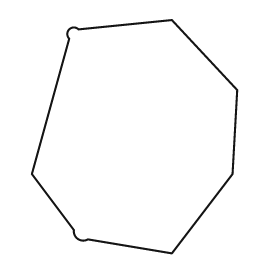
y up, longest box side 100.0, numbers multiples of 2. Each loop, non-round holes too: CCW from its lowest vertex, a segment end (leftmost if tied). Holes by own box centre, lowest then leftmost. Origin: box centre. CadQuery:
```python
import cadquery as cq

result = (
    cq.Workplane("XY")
    .moveTo(16.0, -50.0)
    .lineTo(42.0, -16.0)
    .lineTo(44.0, 20.0)
    .lineTo(16.0, 50.0)
    .lineTo(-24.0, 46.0)
    .threePointArc((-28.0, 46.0), (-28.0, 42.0))
    .lineTo(-44.0, -16.0)
    .lineTo(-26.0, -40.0)
    .threePointArc((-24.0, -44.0), (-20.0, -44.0))
    .close()
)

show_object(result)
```